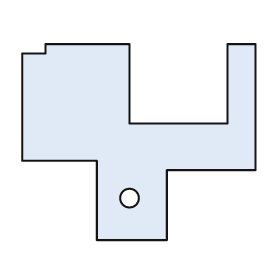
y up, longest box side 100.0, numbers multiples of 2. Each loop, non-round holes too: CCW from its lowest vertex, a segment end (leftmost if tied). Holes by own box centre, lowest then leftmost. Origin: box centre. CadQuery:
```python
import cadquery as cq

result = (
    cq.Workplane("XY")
    .moveTo(-18.0, -42.0)
    .lineTo(12.0, -42.0)
    .lineTo(12.0, -12.0)
    .lineTo(50.0, -12.0)
    .lineTo(50.0, 42.0)
    .lineTo(38.0, 42.0)
    .lineTo(38.0, 8.0)
    .lineTo(-4.0, 8.0)
    .lineTo(-4.0, 42.0)
    .lineTo(-40.0, 42.0)
    .lineTo(-40.0, 38.0)
    .lineTo(-50.0, 38.0)
    .lineTo(-50.0, -8.0)
    .lineTo(-18.0, -8.0)
    .close()
    .moveTo(-4.0, -24.0)
    .circle(4.0)
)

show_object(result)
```